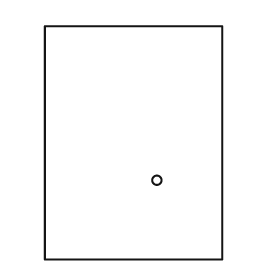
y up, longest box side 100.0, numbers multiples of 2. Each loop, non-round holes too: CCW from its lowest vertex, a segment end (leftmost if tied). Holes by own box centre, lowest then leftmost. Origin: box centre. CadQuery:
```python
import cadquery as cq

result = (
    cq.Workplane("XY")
    .moveTo(-38.0, -50.0)
    .lineTo(38.0, -50.0)
    .lineTo(38.0, 50.0)
    .lineTo(-38.0, 50.0)
    .close()
    .moveTo(10.0, -16.0)
    .circle(2.0)
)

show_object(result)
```